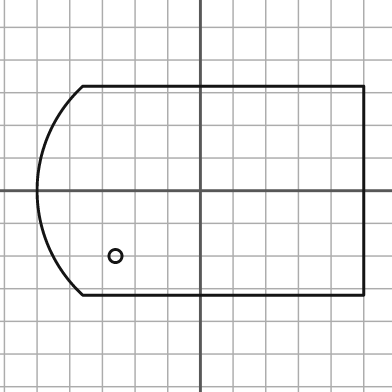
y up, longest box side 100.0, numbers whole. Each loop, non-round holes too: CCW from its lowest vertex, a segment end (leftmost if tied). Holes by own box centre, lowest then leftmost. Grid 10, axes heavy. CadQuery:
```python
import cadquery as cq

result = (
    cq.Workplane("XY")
    .moveTo(-36.0, -32.0)
    .lineTo(50.0, -32.0)
    .lineTo(50.0, 32.0)
    .lineTo(-36.0, 32.0)
    .threePointArc((-50.0, 0.0), (-36.0, -32.0))
    .close()
    .moveTo(-26.0, -20.0)
    .circle(2.0)
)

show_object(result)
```